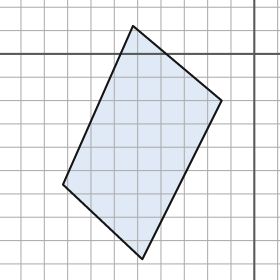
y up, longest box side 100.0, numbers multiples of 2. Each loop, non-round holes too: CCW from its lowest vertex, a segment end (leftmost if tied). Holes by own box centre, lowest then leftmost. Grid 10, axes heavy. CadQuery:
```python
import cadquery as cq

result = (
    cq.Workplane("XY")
    .moveTo(-48.0, -88.0)
    .lineTo(-14.0, -20.0)
    .lineTo(-52.0, 12.0)
    .lineTo(-82.0, -56.0)
    .close()
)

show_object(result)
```